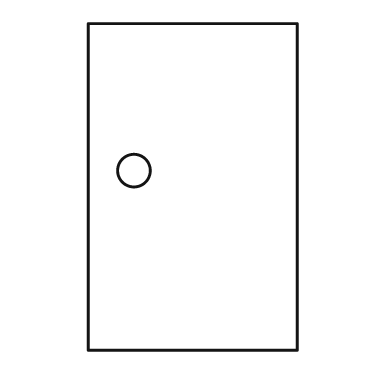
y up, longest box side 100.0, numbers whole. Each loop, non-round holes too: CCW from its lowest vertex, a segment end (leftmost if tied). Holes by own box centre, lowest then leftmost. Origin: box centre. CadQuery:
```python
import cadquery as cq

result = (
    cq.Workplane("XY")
    .moveTo(-32.0, -50.0)
    .lineTo(32.0, -50.0)
    .lineTo(32.0, 50.0)
    .lineTo(-32.0, 50.0)
    .close()
    .moveTo(-18.0, 5.0)
    .circle(5.0)
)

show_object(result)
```